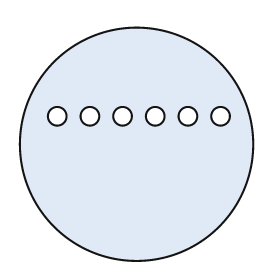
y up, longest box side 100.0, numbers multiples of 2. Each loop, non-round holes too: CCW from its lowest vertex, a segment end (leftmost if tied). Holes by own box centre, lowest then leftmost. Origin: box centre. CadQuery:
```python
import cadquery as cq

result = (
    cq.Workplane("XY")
    .moveTo(0.0, 0.0)
    .circle(50.0)
    .moveTo(-34.0, 12.0)
    .circle(4.0)
    .moveTo(-20.0, 12.0)
    .circle(4.0)
    .moveTo(-6.0, 12.0)
    .circle(4.0)
    .moveTo(8.0, 12.0)
    .circle(4.0)
    .moveTo(22.0, 12.0)
    .circle(4.0)
    .moveTo(36.0, 12.0)
    .circle(4.0)
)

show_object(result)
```